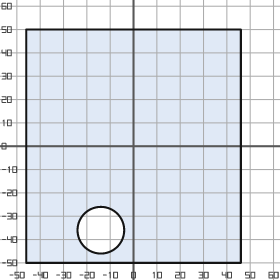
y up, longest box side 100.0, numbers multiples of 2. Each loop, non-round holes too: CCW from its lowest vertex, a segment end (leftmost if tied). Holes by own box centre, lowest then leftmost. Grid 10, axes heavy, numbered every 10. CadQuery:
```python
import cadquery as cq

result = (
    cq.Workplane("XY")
    .moveTo(-46.0, -50.0)
    .lineTo(46.0, -50.0)
    .lineTo(46.0, 50.0)
    .lineTo(-46.0, 50.0)
    .close()
    .moveTo(-14.0, -36.0)
    .circle(10.0)
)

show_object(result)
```